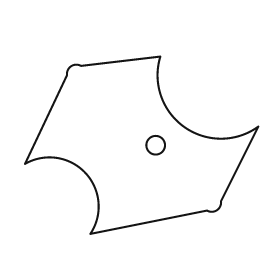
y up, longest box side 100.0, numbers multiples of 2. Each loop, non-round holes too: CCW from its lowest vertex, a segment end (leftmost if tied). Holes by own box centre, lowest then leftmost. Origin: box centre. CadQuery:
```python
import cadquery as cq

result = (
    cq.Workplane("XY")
    .moveTo(-22.0, -38.0)
    .lineTo(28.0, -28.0)
    .threePointArc((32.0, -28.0), (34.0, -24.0))
    .lineTo(50.0, 8.0)
    .threePointArc((18.0, 8.0), (8.0, 38.0))
    .lineTo(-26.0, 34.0)
    .threePointArc((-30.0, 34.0), (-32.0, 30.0))
    .lineTo(-50.0, -8.0)
    .threePointArc((-24.0, -12.0), (-22.0, -38.0))
    .close()
    .moveTo(6.0, 0.0)
    .circle(4.0)
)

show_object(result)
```